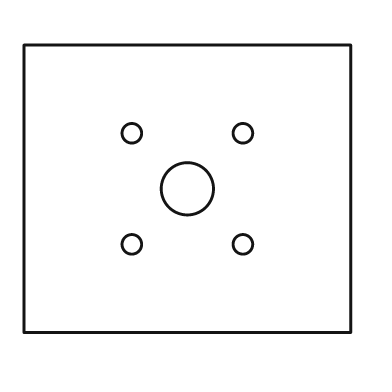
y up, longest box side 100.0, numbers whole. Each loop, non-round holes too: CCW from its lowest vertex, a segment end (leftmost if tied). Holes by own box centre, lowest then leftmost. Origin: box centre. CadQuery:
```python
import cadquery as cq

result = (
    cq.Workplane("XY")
    .moveTo(-50.0, -44.0)
    .lineTo(50.0, -44.0)
    .lineTo(50.0, 44.0)
    .lineTo(-50.0, 44.0)
    .close()
    .moveTo(-17.0, -17.0)
    .circle(3.0)
    .moveTo(17.0, -17.0)
    .circle(3.0)
    .moveTo(0.0, 0.0)
    .circle(8.0)
    .moveTo(-17.0, 17.0)
    .circle(3.0)
    .moveTo(17.0, 17.0)
    .circle(3.0)
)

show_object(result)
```